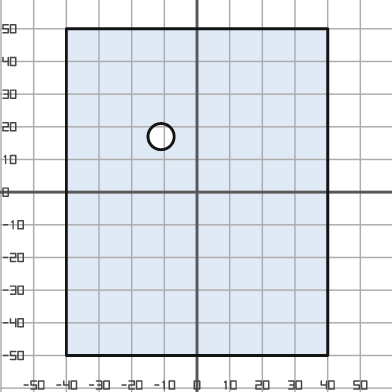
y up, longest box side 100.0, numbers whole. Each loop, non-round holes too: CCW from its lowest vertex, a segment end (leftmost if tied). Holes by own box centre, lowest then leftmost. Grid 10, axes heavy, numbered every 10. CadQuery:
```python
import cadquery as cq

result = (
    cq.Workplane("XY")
    .moveTo(-40.0, -50.0)
    .lineTo(40.0, -50.0)
    .lineTo(40.0, 50.0)
    .lineTo(-40.0, 50.0)
    .close()
    .moveTo(-11.0, 17.0)
    .circle(4.0)
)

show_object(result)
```